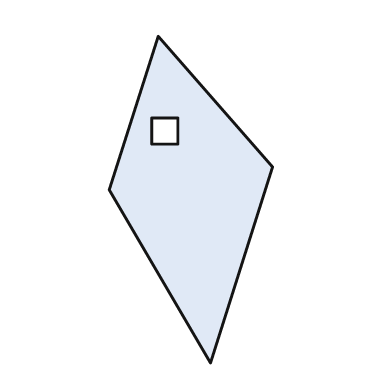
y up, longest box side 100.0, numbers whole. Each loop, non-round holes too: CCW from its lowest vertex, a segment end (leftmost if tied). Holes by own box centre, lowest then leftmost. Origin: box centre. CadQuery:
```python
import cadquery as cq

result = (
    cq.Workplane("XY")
    .moveTo(6.0, -50.0)
    .lineTo(25.0, 10.0)
    .lineTo(-10.0, 50.0)
    .lineTo(-25.0, 3.0)
    .close()
    .moveTo(-12.0, 17.0)
    .lineTo(-4.0, 17.0)
    .lineTo(-4.0, 25.0)
    .lineTo(-12.0, 25.0)
    .close()
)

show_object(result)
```